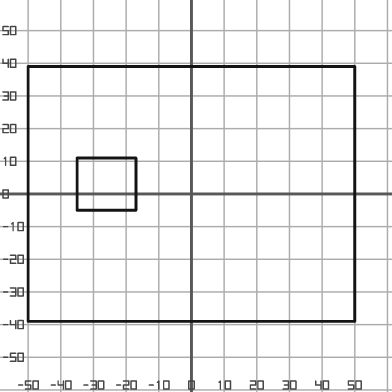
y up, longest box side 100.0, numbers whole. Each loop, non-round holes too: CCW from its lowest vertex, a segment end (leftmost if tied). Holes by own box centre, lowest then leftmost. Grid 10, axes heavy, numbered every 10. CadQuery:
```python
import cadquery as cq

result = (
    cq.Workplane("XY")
    .moveTo(-50.0, -39.0)
    .lineTo(50.0, -39.0)
    .lineTo(50.0, 39.0)
    .lineTo(-50.0, 39.0)
    .close()
    .moveTo(-35.0, -5.0)
    .lineTo(-17.0, -5.0)
    .lineTo(-17.0, 11.0)
    .lineTo(-35.0, 11.0)
    .close()
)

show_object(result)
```